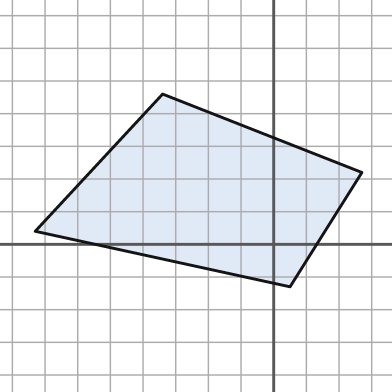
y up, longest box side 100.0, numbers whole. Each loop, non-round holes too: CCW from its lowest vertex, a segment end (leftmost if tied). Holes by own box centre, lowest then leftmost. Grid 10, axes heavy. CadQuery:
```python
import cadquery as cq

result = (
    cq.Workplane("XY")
    .moveTo(5.0, -13.0)
    .lineTo(27.0, 22.0)
    .lineTo(-34.0, 46.0)
    .lineTo(-73.0, 4.0)
    .close()
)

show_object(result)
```